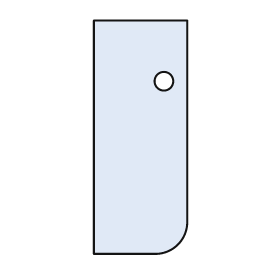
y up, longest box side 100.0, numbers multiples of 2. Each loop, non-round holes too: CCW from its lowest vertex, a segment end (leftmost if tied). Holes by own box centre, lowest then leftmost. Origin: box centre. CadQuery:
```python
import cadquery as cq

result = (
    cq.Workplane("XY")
    .moveTo(-20.0, -50.0)
    .lineTo(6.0, -50.0)
    .threePointArc((16.0, -46.0), (20.0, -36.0))
    .lineTo(20.0, 50.0)
    .lineTo(-20.0, 50.0)
    .close()
    .moveTo(10.0, 24.0)
    .circle(4.0)
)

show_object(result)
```